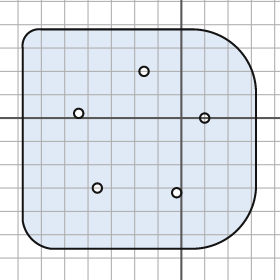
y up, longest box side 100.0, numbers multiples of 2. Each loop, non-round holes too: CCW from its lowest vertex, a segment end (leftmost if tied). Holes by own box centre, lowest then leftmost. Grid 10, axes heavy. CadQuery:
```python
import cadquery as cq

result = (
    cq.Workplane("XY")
    .moveTo(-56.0, -56.0)
    .lineTo(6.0, -56.0)
    .threePointArc((24.0, -48.0), (32.0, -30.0))
    .lineTo(32.0, 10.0)
    .threePointArc((24.0, 30.0), (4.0, 38.0))
    .lineTo(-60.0, 38.0)
    .threePointArc((-66.0, 36.0), (-68.0, 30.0))
    .lineTo(-68.0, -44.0)
    .threePointArc((-64.0, -52.0), (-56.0, -56.0))
    .close()
    .moveTo(-2.0, -32.0)
    .circle(2.0)
    .moveTo(-36.0, -30.0)
    .circle(2.0)
    .moveTo(10.0, 0.0)
    .circle(2.0)
    .moveTo(-44.0, 2.0)
    .circle(2.0)
    .moveTo(-16.0, 20.0)
    .circle(2.0)
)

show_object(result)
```